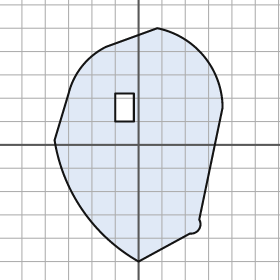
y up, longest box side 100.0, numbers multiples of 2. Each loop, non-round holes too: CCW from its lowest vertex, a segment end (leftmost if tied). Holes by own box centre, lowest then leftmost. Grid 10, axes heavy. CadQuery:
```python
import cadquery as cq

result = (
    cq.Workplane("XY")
    .moveTo(0.0, -50.0)
    .lineTo(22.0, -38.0)
    .threePointArc((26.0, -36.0), (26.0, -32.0))
    .lineTo(36.0, 16.0)
    .threePointArc((28.0, 38.0), (8.0, 50.0))
    .lineTo(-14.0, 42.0)
    .threePointArc((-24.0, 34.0), (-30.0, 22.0))
    .lineTo(-36.0, 2.0)
    .threePointArc((-24.0, -28.0), (0.0, -50.0))
    .close()
    .moveTo(-10.0, 10.0)
    .lineTo(-2.0, 10.0)
    .lineTo(-2.0, 22.0)
    .lineTo(-10.0, 22.0)
    .close()
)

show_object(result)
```